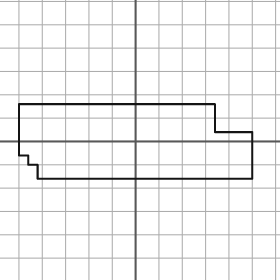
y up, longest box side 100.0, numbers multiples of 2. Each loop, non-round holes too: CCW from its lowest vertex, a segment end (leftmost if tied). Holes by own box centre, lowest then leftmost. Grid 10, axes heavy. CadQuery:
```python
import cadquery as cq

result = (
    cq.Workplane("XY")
    .moveTo(-42.0, -16.0)
    .lineTo(50.0, -16.0)
    .lineTo(50.0, 4.0)
    .lineTo(34.0, 4.0)
    .lineTo(34.0, 16.0)
    .lineTo(-50.0, 16.0)
    .lineTo(-50.0, -6.0)
    .lineTo(-46.0, -6.0)
    .lineTo(-46.0, -10.0)
    .lineTo(-42.0, -10.0)
    .close()
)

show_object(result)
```